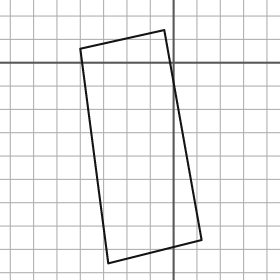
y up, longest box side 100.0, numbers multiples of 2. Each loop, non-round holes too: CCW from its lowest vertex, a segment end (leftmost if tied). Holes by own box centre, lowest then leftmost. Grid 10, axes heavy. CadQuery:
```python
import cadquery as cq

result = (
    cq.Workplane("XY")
    .moveTo(-28.0, -86.0)
    .lineTo(12.0, -76.0)
    .lineTo(-4.0, 14.0)
    .lineTo(-40.0, 6.0)
    .close()
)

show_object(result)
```